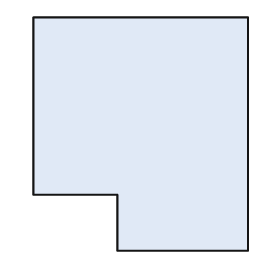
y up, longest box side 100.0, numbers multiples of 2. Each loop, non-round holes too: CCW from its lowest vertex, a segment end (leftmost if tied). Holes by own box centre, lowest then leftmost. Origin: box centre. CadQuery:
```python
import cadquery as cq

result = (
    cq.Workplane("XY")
    .moveTo(-10.0, -50.0)
    .lineTo(46.0, -50.0)
    .lineTo(46.0, 50.0)
    .lineTo(-46.0, 50.0)
    .lineTo(-46.0, -26.0)
    .lineTo(-10.0, -26.0)
    .close()
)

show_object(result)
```